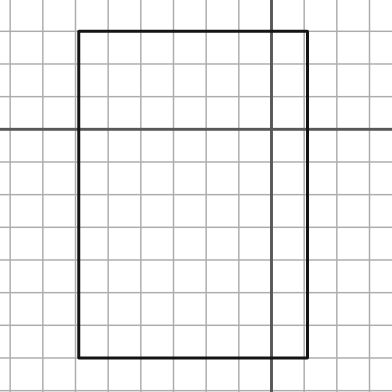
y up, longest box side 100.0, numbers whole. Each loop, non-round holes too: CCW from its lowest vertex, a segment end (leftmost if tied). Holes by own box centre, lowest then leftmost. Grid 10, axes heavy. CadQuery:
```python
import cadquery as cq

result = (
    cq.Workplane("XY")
    .moveTo(-59.0, -70.0)
    .lineTo(11.0, -70.0)
    .lineTo(11.0, 30.0)
    .lineTo(-59.0, 30.0)
    .close()
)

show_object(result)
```